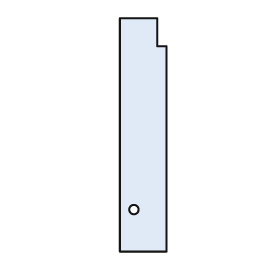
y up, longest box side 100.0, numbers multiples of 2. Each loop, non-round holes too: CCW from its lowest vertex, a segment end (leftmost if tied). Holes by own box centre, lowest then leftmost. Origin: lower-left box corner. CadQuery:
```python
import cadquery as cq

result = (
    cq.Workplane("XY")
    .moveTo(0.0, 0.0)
    .lineTo(20.0, 0.0)
    .lineTo(20.0, 88.0)
    .lineTo(16.0, 88.0)
    .lineTo(16.0, 100.0)
    .lineTo(0.0, 100.0)
    .close()
    .moveTo(6.0, 18.0)
    .circle(2.0)
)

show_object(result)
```